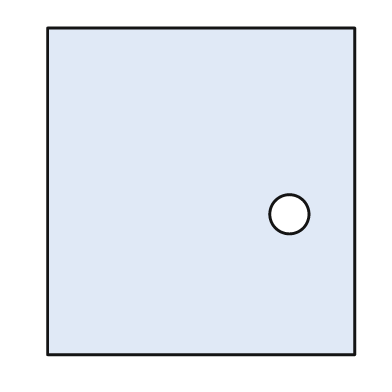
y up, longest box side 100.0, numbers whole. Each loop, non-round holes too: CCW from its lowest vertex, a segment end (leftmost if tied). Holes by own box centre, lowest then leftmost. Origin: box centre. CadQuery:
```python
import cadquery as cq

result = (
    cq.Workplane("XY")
    .moveTo(-47.0, -50.0)
    .lineTo(47.0, -50.0)
    .lineTo(47.0, 50.0)
    .lineTo(-47.0, 50.0)
    .close()
    .moveTo(27.0, -7.0)
    .circle(6.0)
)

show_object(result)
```